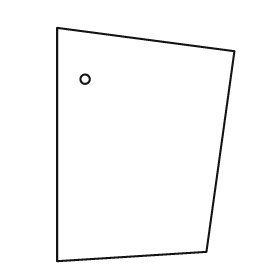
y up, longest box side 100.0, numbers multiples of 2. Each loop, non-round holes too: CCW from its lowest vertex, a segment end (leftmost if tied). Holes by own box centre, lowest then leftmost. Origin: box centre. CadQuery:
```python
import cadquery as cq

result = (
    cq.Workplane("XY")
    .moveTo(-38.0, -50.0)
    .lineTo(26.0, -46.0)
    .lineTo(38.0, 40.0)
    .lineTo(-38.0, 50.0)
    .close()
    .moveTo(-26.0, 28.0)
    .circle(2.0)
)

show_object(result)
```